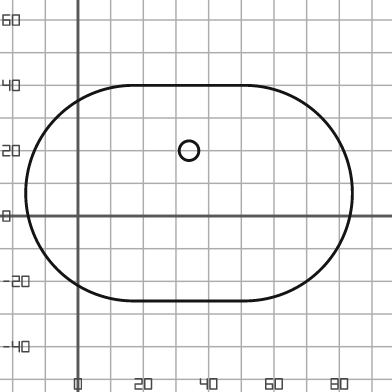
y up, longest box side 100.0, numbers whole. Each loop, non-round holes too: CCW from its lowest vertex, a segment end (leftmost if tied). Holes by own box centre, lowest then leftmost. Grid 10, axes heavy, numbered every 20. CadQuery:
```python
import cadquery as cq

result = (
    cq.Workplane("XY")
    .moveTo(17.0, -26.0)
    .lineTo(51.0, -26.0)
    .threePointArc((84.0, 7.0), (51.0, 40.0))
    .lineTo(17.0, 40.0)
    .threePointArc((-16.0, 7.0), (17.0, -26.0))
    .close()
    .moveTo(34.0, 20.0)
    .circle(3.0)
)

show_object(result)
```